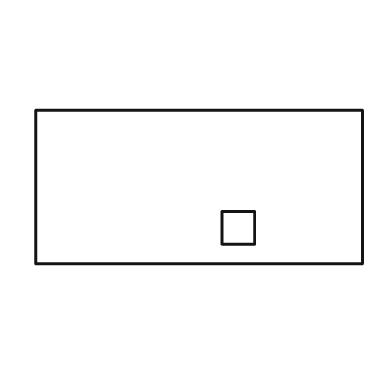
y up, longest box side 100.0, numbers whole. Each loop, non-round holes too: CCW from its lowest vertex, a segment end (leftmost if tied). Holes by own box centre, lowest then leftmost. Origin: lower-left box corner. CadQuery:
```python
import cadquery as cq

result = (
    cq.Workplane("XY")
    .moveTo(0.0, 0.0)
    .lineTo(100.0, 0.0)
    .lineTo(100.0, 47.0)
    .lineTo(0.0, 47.0)
    .close()
    .moveTo(57.0, 6.0)
    .lineTo(67.0, 6.0)
    .lineTo(67.0, 16.0)
    .lineTo(57.0, 16.0)
    .close()
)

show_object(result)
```